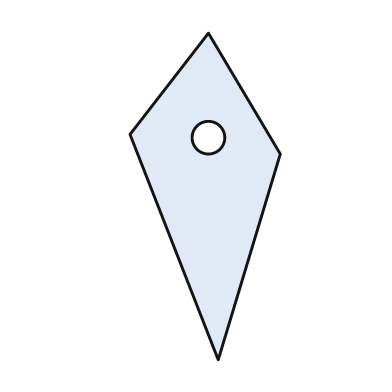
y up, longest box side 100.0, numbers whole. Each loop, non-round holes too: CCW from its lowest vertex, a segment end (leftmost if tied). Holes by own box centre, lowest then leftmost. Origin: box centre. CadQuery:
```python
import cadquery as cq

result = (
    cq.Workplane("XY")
    .moveTo(4.0, -50.0)
    .lineTo(23.0, 13.0)
    .lineTo(1.0, 50.0)
    .lineTo(-23.0, 19.0)
    .close()
    .moveTo(1.0, 18.0)
    .circle(5.0)
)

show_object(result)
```